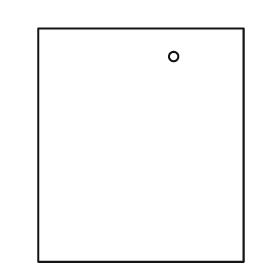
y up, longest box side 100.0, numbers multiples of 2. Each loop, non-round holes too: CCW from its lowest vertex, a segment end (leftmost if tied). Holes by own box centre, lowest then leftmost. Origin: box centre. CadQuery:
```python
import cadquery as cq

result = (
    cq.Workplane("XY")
    .moveTo(-44.0, -50.0)
    .lineTo(44.0, -50.0)
    .lineTo(44.0, 50.0)
    .lineTo(-44.0, 50.0)
    .close()
    .moveTo(14.0, 38.0)
    .circle(2.0)
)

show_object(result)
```